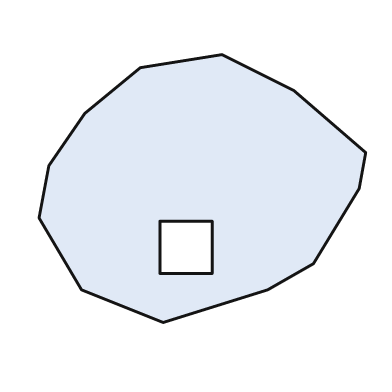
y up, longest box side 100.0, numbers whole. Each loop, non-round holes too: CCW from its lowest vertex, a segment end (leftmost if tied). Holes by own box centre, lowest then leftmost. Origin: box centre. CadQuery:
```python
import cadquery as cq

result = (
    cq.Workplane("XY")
    .moveTo(-12.0, -41.0)
    .lineTo(20.0, -31.0)
    .lineTo(34.0, -23.0)
    .lineTo(48.0, 0.0)
    .lineTo(50.0, 11.0)
    .lineTo(28.0, 30.0)
    .lineTo(6.0, 41.0)
    .lineTo(-19.0, 37.0)
    .lineTo(-36.0, 23.0)
    .lineTo(-47.0, 7.0)
    .lineTo(-50.0, -9.0)
    .lineTo(-37.0, -31.0)
    .close()
    .moveTo(-13.0, -26.0)
    .lineTo(3.0, -26.0)
    .lineTo(3.0, -10.0)
    .lineTo(-13.0, -10.0)
    .close()
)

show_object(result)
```